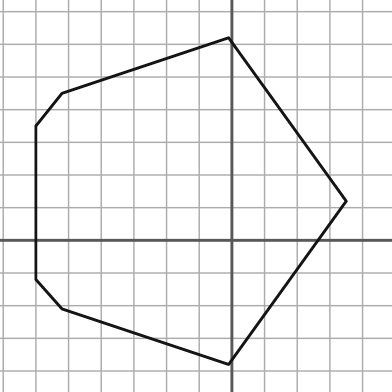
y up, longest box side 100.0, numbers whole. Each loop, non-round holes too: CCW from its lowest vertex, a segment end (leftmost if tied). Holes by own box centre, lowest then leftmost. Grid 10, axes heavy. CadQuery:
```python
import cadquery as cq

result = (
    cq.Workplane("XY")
    .moveTo(-1.0, -38.0)
    .lineTo(35.0, 12.0)
    .lineTo(-1.0, 62.0)
    .lineTo(-52.0, 45.0)
    .lineTo(-60.0, 35.0)
    .lineTo(-60.0, -12.0)
    .lineTo(-52.0, -21.0)
    .close()
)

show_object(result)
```